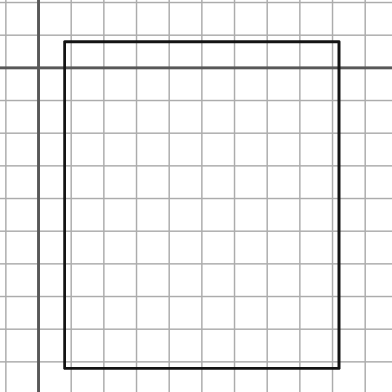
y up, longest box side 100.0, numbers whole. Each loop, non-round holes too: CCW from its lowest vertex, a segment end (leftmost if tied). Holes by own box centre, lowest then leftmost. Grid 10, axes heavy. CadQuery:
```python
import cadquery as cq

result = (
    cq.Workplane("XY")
    .moveTo(8.0, -92.0)
    .lineTo(92.0, -92.0)
    .lineTo(92.0, 8.0)
    .lineTo(8.0, 8.0)
    .close()
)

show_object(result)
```